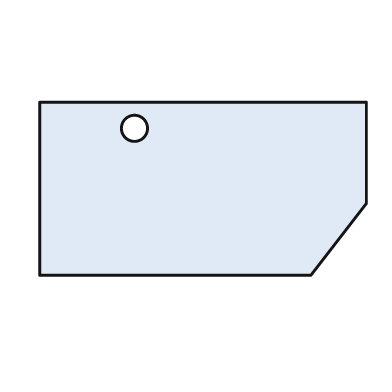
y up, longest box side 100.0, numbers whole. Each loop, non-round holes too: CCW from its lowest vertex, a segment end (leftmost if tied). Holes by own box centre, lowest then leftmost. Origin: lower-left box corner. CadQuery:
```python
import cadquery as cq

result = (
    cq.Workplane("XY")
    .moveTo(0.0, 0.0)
    .lineTo(83.0, 0.0)
    .lineTo(100.0, 22.0)
    .lineTo(100.0, 53.0)
    .lineTo(0.0, 53.0)
    .close()
    .moveTo(29.0, 45.0)
    .circle(4.0)
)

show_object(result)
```